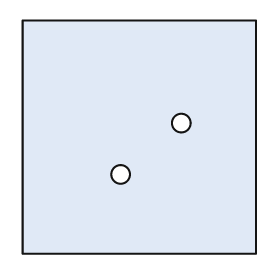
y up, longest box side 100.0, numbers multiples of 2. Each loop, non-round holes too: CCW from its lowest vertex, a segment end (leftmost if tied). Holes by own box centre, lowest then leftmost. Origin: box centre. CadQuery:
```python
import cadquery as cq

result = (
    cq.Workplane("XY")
    .moveTo(-50.0, -50.0)
    .lineTo(50.0, -50.0)
    .lineTo(50.0, 50.0)
    .lineTo(-50.0, 50.0)
    .close()
    .moveTo(-8.0, -16.0)
    .circle(4.0)
    .moveTo(18.0, 6.0)
    .circle(4.0)
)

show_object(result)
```